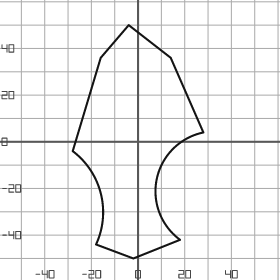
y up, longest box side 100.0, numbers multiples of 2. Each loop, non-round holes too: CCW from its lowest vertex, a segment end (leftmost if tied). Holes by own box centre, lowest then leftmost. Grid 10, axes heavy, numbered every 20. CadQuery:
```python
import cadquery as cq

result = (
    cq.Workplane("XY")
    .moveTo(-2.0, -50.0)
    .lineTo(18.0, -42.0)
    .threePointArc((8.0, -16.0), (28.0, 4.0))
    .lineTo(14.0, 36.0)
    .lineTo(-4.0, 50.0)
    .lineTo(-16.0, 36.0)
    .lineTo(-28.0, -4.0)
    .threePointArc((-16.0, -22.0), (-18.0, -44.0))
    .close()
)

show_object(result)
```